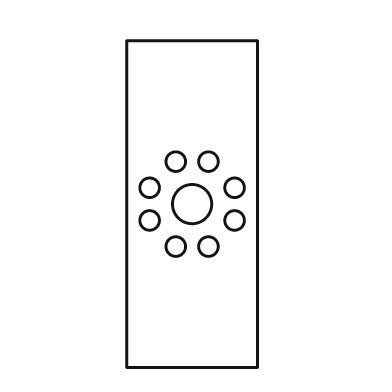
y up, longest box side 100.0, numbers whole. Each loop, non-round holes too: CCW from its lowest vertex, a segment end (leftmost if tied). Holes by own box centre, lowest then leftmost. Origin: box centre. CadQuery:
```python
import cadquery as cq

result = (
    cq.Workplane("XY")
    .moveTo(-20.0, -50.0)
    .lineTo(20.0, -50.0)
    .lineTo(20.0, 50.0)
    .lineTo(-20.0, 50.0)
    .close()
    .moveTo(-5.0, -13.0)
    .circle(3.0)
    .moveTo(5.0, -13.0)
    .circle(3.0)
    .moveTo(-13.0, -5.0)
    .circle(3.0)
    .moveTo(13.0, -5.0)
    .circle(3.0)
    .moveTo(0.0, 0.0)
    .circle(6.0)
    .moveTo(-13.0, 5.0)
    .circle(3.0)
    .moveTo(13.0, 5.0)
    .circle(3.0)
    .moveTo(-5.0, 13.0)
    .circle(3.0)
    .moveTo(5.0, 13.0)
    .circle(3.0)
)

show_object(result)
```